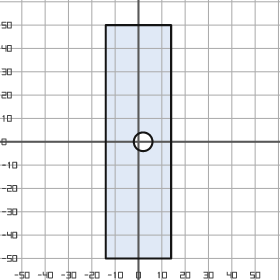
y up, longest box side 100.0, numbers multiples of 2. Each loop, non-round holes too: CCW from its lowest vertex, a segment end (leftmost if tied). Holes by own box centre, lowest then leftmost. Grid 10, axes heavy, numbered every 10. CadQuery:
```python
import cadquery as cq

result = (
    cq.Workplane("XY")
    .moveTo(-14.0, -50.0)
    .lineTo(14.0, -50.0)
    .lineTo(14.0, 50.0)
    .lineTo(-14.0, 50.0)
    .close()
    .moveTo(2.0, 0.0)
    .circle(4.0)
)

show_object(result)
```